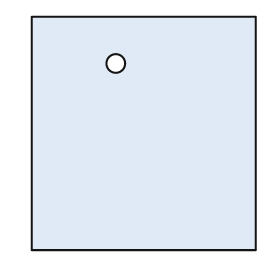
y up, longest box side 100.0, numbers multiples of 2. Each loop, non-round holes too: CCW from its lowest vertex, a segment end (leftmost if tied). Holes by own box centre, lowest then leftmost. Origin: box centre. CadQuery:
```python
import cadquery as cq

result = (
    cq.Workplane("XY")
    .moveTo(-48.0, -50.0)
    .lineTo(48.0, -50.0)
    .lineTo(48.0, 50.0)
    .lineTo(-48.0, 50.0)
    .close()
    .moveTo(-12.0, 30.0)
    .circle(4.0)
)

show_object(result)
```